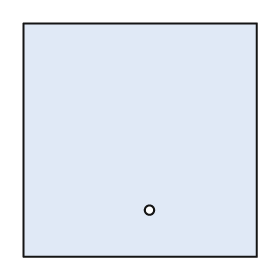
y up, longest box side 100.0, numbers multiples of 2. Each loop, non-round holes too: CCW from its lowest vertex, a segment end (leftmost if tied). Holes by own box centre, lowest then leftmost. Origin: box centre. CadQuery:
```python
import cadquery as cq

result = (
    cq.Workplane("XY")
    .moveTo(-50.0, -50.0)
    .lineTo(50.0, -50.0)
    .lineTo(50.0, 50.0)
    .lineTo(-50.0, 50.0)
    .close()
    .moveTo(4.0, -30.0)
    .circle(2.0)
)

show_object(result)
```